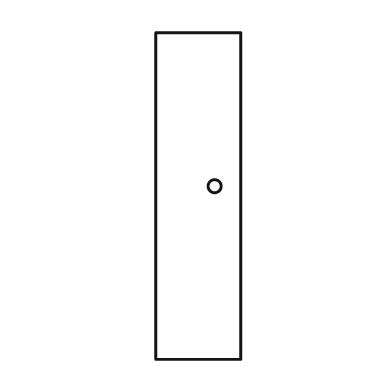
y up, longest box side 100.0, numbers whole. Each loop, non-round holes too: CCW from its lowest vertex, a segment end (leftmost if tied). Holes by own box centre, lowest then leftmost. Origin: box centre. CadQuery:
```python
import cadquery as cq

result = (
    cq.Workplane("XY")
    .moveTo(-13.0, -50.0)
    .lineTo(13.0, -50.0)
    .lineTo(13.0, 50.0)
    .lineTo(-13.0, 50.0)
    .close()
    .moveTo(5.0, 3.0)
    .circle(2.0)
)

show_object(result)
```